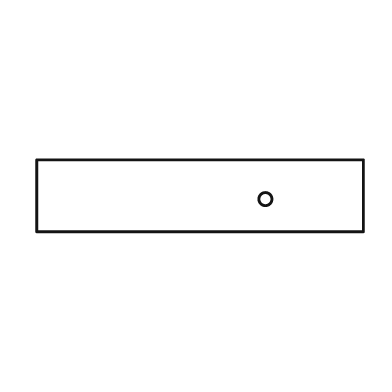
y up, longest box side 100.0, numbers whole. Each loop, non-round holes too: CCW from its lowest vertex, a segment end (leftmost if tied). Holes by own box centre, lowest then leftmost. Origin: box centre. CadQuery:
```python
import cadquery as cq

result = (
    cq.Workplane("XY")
    .moveTo(-50.0, -11.0)
    .lineTo(50.0, -11.0)
    .lineTo(50.0, 11.0)
    .lineTo(-50.0, 11.0)
    .close()
    .moveTo(20.0, -1.0)
    .circle(2.0)
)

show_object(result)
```